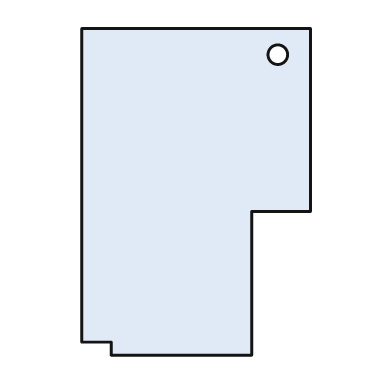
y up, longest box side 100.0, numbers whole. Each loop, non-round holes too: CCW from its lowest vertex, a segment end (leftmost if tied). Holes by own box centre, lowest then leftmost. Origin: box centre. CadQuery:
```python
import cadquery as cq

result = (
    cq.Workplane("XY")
    .moveTo(-26.0, -50.0)
    .lineTo(17.0, -50.0)
    .lineTo(17.0, -6.0)
    .lineTo(35.0, -6.0)
    .lineTo(35.0, 50.0)
    .lineTo(-35.0, 50.0)
    .lineTo(-35.0, -46.0)
    .lineTo(-26.0, -46.0)
    .close()
    .moveTo(25.0, 42.0)
    .circle(3.0)
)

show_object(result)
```